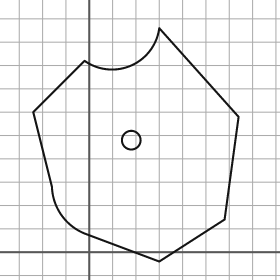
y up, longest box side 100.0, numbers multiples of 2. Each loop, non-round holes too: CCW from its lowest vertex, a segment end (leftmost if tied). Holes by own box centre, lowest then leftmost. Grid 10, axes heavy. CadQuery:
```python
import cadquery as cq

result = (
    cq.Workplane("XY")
    .moveTo(30.0, -4.0)
    .lineTo(58.0, 14.0)
    .lineTo(64.0, 58.0)
    .lineTo(30.0, 96.0)
    .threePointArc((18.0, 80.0), (-2.0, 82.0))
    .lineTo(-24.0, 60.0)
    .lineTo(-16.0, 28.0)
    .threePointArc((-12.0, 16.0), (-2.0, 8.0))
    .close()
    .moveTo(18.0, 48.0)
    .circle(4.0)
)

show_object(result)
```